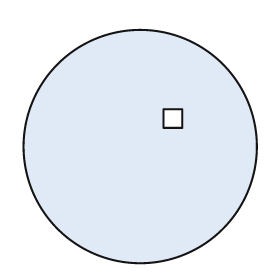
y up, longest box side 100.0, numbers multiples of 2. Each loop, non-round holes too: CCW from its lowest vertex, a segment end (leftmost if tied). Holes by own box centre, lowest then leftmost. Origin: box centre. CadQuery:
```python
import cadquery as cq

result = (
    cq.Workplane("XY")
    .moveTo(0.0, 0.0)
    .circle(50.0)
    .moveTo(10.0, 8.0)
    .lineTo(18.0, 8.0)
    .lineTo(18.0, 16.0)
    .lineTo(10.0, 16.0)
    .close()
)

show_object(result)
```